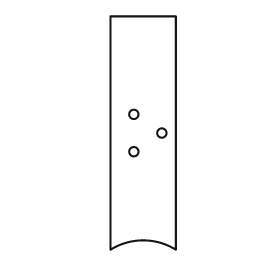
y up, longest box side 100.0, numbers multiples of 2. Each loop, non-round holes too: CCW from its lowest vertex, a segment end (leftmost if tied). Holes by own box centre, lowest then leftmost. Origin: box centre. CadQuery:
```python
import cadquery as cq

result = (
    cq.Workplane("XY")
    .moveTo(-14.0, -50.0)
    .threePointArc((0.0, -46.0), (14.0, -50.0))
    .lineTo(14.0, 50.0)
    .lineTo(-14.0, 50.0)
    .close()
    .moveTo(-4.0, -8.0)
    .circle(2.0)
    .moveTo(8.0, 0.0)
    .circle(2.0)
    .moveTo(-4.0, 8.0)
    .circle(2.0)
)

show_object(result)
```